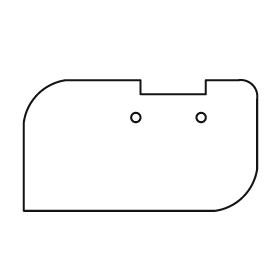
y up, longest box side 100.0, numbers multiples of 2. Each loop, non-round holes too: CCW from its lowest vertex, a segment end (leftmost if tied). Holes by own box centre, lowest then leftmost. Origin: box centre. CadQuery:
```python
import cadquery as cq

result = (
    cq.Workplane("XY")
    .moveTo(-50.0, -28.0)
    .lineTo(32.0, -28.0)
    .threePointArc((44.0, -22.0), (50.0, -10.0))
    .lineTo(50.0, 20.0)
    .threePointArc((48.0, 26.0), (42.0, 28.0))
    .lineTo(28.0, 28.0)
    .lineTo(28.0, 22.0)
    .lineTo(0.0, 22.0)
    .lineTo(0.0, 28.0)
    .lineTo(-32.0, 28.0)
    .threePointArc((-44.0, 22.0), (-50.0, 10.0))
    .close()
    .moveTo(-2.0, 12.0)
    .circle(2.0)
    .moveTo(26.0, 12.0)
    .circle(2.0)
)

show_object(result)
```